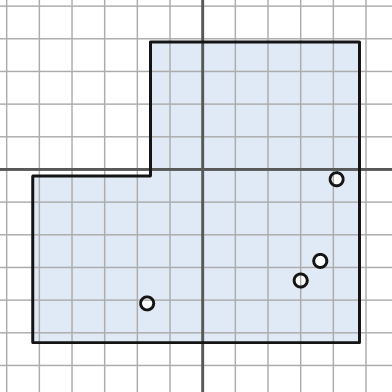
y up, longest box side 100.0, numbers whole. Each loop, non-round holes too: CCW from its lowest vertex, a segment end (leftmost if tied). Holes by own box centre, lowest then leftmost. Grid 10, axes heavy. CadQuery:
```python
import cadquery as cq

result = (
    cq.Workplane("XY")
    .moveTo(-52.0, -53.0)
    .lineTo(48.0, -53.0)
    .lineTo(48.0, 39.0)
    .lineTo(-16.0, 39.0)
    .lineTo(-16.0, -2.0)
    .lineTo(-52.0, -2.0)
    .close()
    .moveTo(-17.0, -41.0)
    .circle(2.0)
    .moveTo(30.0, -34.0)
    .circle(2.0)
    .moveTo(36.0, -28.0)
    .circle(2.0)
    .moveTo(41.0, -3.0)
    .circle(2.0)
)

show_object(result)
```